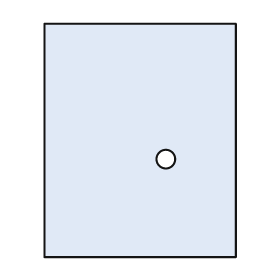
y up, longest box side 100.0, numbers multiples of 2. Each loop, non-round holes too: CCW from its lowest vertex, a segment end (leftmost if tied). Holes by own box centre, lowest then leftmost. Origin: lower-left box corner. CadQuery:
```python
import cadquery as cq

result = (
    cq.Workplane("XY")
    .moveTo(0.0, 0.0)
    .lineTo(82.0, 0.0)
    .lineTo(82.0, 100.0)
    .lineTo(0.0, 100.0)
    .close()
    .moveTo(52.0, 42.0)
    .circle(4.0)
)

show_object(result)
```